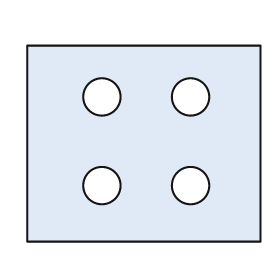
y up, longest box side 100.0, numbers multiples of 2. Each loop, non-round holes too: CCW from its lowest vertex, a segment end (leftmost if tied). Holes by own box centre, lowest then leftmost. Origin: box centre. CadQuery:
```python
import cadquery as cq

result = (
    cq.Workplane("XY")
    .moveTo(-50.0, -42.0)
    .lineTo(50.0, -42.0)
    .lineTo(50.0, 42.0)
    .lineTo(-50.0, 42.0)
    .close()
    .moveTo(-18.0, -18.0)
    .circle(8.0)
    .moveTo(20.0, -18.0)
    .circle(8.0)
    .moveTo(-18.0, 20.0)
    .circle(8.0)
    .moveTo(20.0, 20.0)
    .circle(8.0)
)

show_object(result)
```